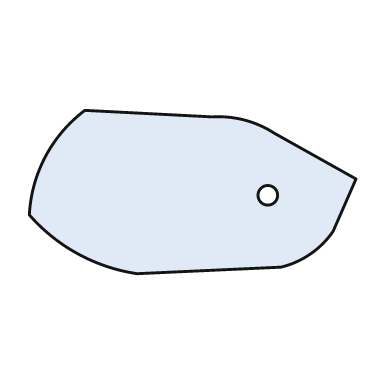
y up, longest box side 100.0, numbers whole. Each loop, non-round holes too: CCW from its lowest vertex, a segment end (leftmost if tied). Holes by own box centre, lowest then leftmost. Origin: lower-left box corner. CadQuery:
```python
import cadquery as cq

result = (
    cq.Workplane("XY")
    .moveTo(33.0, 0.0)
    .lineTo(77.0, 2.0)
    .threePointArc((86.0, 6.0), (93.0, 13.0))
    .lineTo(100.0, 29.0)
    .lineTo(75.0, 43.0)
    .threePointArc((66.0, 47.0), (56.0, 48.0))
    .lineTo(17.0, 50.0)
    .threePointArc((5.0, 36.0), (0.0, 18.0))
    .threePointArc((15.0, 6.0), (33.0, 0.0))
    .close()
    .moveTo(73.0, 24.0)
    .circle(3.0)
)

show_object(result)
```